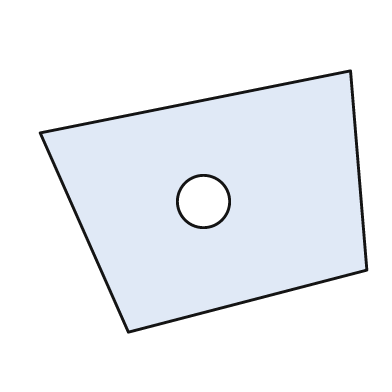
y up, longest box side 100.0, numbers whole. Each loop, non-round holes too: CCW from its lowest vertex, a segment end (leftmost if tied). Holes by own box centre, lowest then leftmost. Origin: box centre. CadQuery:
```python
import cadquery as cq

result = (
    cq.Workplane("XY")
    .moveTo(-23.0, -40.0)
    .lineTo(50.0, -21.0)
    .lineTo(45.0, 40.0)
    .lineTo(-50.0, 21.0)
    .close()
    .moveTo(0.0, 0.0)
    .circle(8.0)
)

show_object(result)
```